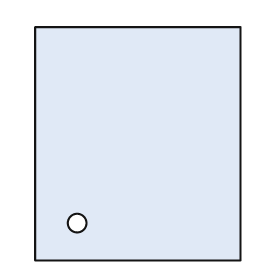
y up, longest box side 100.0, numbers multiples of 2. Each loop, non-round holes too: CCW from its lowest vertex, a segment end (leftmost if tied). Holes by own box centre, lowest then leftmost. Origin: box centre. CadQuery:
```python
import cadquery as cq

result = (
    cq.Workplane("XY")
    .moveTo(-44.0, -50.0)
    .lineTo(44.0, -50.0)
    .lineTo(44.0, 50.0)
    .lineTo(-44.0, 50.0)
    .close()
    .moveTo(-26.0, -34.0)
    .circle(4.0)
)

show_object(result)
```